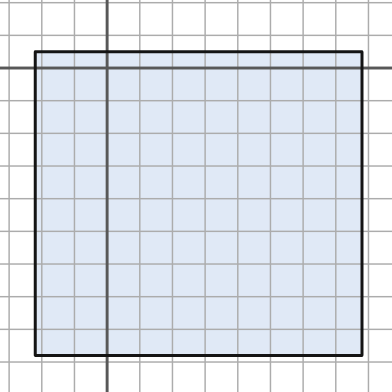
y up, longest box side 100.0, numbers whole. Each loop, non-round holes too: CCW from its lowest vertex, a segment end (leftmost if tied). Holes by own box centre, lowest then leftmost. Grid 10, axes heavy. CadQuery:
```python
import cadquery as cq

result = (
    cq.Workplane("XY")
    .moveTo(-22.0, -88.0)
    .lineTo(78.0, -88.0)
    .lineTo(78.0, 5.0)
    .lineTo(-22.0, 5.0)
    .close()
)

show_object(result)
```